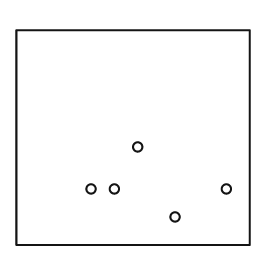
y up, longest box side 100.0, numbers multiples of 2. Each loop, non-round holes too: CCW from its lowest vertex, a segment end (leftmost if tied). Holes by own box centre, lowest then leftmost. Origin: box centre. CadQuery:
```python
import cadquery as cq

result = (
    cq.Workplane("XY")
    .moveTo(-50.0, -46.0)
    .lineTo(50.0, -46.0)
    .lineTo(50.0, 46.0)
    .lineTo(-50.0, 46.0)
    .close()
    .moveTo(18.0, -34.0)
    .circle(2.0)
    .moveTo(-18.0, -22.0)
    .circle(2.0)
    .moveTo(-8.0, -22.0)
    .circle(2.0)
    .moveTo(40.0, -22.0)
    .circle(2.0)
    .moveTo(2.0, -4.0)
    .circle(2.0)
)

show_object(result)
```